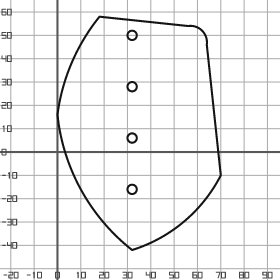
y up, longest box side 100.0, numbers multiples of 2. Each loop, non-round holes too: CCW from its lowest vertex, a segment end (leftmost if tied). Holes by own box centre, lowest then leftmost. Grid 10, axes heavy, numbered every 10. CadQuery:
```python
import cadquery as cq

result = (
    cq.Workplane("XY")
    .moveTo(32.0, -42.0)
    .threePointArc((54.0, -30.0), (70.0, -10.0))
    .lineTo(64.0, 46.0)
    .threePointArc((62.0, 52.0), (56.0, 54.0))
    .lineTo(18.0, 58.0)
    .threePointArc((6.0, 38.0), (0.0, 16.0))
    .threePointArc((10.0, -16.0), (32.0, -42.0))
    .close()
    .moveTo(32.0, -16.0)
    .circle(2.0)
    .moveTo(32.0, 6.0)
    .circle(2.0)
    .moveTo(32.0, 28.0)
    .circle(2.0)
    .moveTo(32.0, 50.0)
    .circle(2.0)
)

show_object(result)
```